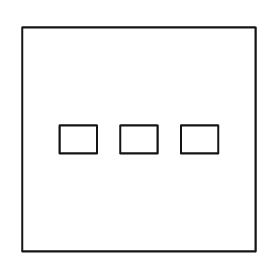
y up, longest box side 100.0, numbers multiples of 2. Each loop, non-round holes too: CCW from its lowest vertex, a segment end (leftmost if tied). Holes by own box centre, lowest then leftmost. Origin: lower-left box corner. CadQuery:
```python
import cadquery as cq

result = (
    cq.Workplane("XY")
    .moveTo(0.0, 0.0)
    .lineTo(100.0, 0.0)
    .lineTo(100.0, 96.0)
    .lineTo(0.0, 96.0)
    .close()
    .moveTo(16.0, 42.0)
    .lineTo(32.0, 42.0)
    .lineTo(32.0, 54.0)
    .lineTo(16.0, 54.0)
    .close()
    .moveTo(42.0, 42.0)
    .lineTo(58.0, 42.0)
    .lineTo(58.0, 54.0)
    .lineTo(42.0, 54.0)
    .close()
    .moveTo(68.0, 42.0)
    .lineTo(84.0, 42.0)
    .lineTo(84.0, 54.0)
    .lineTo(68.0, 54.0)
    .close()
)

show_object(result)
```